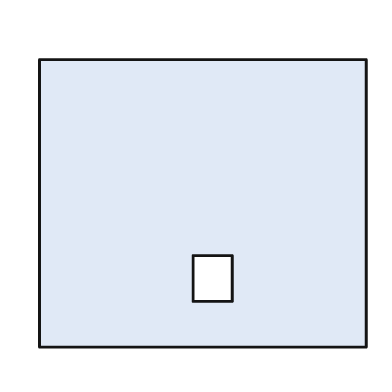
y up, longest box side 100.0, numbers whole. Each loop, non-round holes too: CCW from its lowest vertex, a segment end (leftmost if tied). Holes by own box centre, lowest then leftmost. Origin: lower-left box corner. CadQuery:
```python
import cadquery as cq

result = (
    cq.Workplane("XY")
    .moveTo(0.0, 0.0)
    .lineTo(100.0, 0.0)
    .lineTo(100.0, 88.0)
    .lineTo(0.0, 88.0)
    .close()
    .moveTo(47.0, 14.0)
    .lineTo(59.0, 14.0)
    .lineTo(59.0, 28.0)
    .lineTo(47.0, 28.0)
    .close()
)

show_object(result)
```